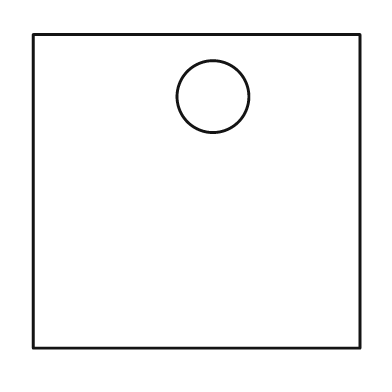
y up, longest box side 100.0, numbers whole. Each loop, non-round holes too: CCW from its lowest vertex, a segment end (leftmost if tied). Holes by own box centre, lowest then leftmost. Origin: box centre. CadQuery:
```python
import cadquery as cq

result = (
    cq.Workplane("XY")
    .moveTo(-50.0, -48.0)
    .lineTo(50.0, -48.0)
    .lineTo(50.0, 48.0)
    .lineTo(-50.0, 48.0)
    .close()
    .moveTo(5.0, 29.0)
    .circle(11.0)
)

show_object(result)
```